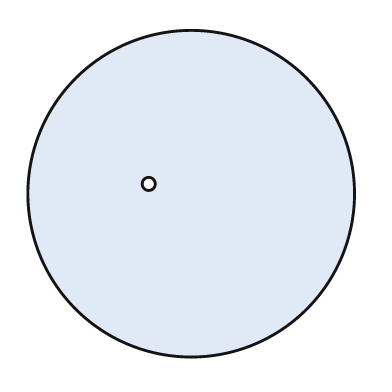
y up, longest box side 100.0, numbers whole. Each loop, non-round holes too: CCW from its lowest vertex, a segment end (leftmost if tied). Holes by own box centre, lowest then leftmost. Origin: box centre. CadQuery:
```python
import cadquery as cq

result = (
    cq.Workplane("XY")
    .moveTo(0.0, 0.0)
    .circle(50.0)
    .moveTo(-13.0, 3.0)
    .circle(2.0)
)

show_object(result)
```